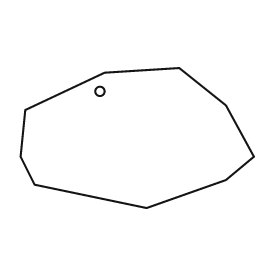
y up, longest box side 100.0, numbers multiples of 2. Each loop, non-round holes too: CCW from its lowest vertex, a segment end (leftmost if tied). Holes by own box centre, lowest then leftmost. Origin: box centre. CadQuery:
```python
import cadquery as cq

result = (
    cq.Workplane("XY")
    .moveTo(4.0, -30.0)
    .lineTo(38.0, -18.0)
    .lineTo(50.0, -8.0)
    .lineTo(38.0, 14.0)
    .lineTo(18.0, 30.0)
    .lineTo(-14.0, 28.0)
    .lineTo(-48.0, 12.0)
    .lineTo(-50.0, -8.0)
    .lineTo(-44.0, -20.0)
    .close()
    .moveTo(-16.0, 20.0)
    .circle(2.0)
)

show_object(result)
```